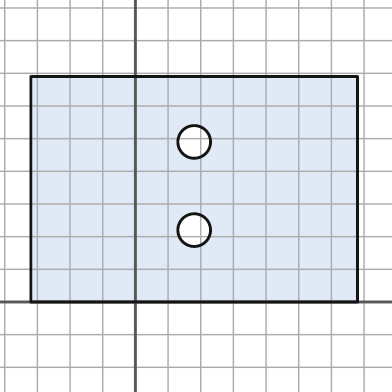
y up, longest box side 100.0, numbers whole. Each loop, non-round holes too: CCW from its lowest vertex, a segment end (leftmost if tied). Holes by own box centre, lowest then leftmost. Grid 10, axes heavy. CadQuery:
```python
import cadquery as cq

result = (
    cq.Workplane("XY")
    .moveTo(-32.0, 0.0)
    .lineTo(68.0, 0.0)
    .lineTo(68.0, 69.0)
    .lineTo(-32.0, 69.0)
    .close()
    .moveTo(18.0, 22.0)
    .circle(5.0)
    .moveTo(18.0, 49.0)
    .circle(5.0)
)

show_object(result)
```